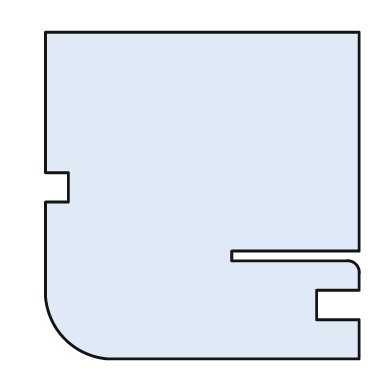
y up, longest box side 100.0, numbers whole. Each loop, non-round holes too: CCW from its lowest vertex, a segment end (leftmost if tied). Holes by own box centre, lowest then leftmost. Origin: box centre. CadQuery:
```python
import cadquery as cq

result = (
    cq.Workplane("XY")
    .moveTo(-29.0, -50.0)
    .lineTo(48.0, -50.0)
    .lineTo(48.0, -38.0)
    .lineTo(35.0, -38.0)
    .lineTo(35.0, -29.0)
    .lineTo(48.0, -29.0)
    .lineTo(48.0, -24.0)
    .threePointArc((47.0, -21.0), (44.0, -20.0))
    .lineTo(9.0, -20.0)
    .lineTo(9.0, -17.0)
    .lineTo(48.0, -17.0)
    .lineTo(48.0, 50.0)
    .lineTo(-48.0, 50.0)
    .lineTo(-48.0, 7.0)
    .lineTo(-41.0, 7.0)
    .lineTo(-41.0, -2.0)
    .lineTo(-48.0, -2.0)
    .lineTo(-48.0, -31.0)
    .threePointArc((-42.0, -44.0), (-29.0, -50.0))
    .close()
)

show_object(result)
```